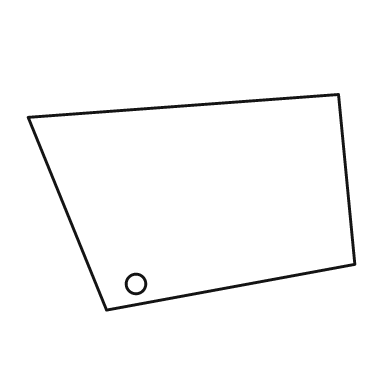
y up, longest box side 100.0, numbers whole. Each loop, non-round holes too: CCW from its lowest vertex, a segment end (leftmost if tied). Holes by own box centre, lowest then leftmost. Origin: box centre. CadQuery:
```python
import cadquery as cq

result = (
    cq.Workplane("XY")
    .moveTo(-26.0, -33.0)
    .lineTo(50.0, -19.0)
    .lineTo(45.0, 33.0)
    .lineTo(-50.0, 26.0)
    .close()
    .moveTo(-17.0, -25.0)
    .circle(3.0)
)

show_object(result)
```